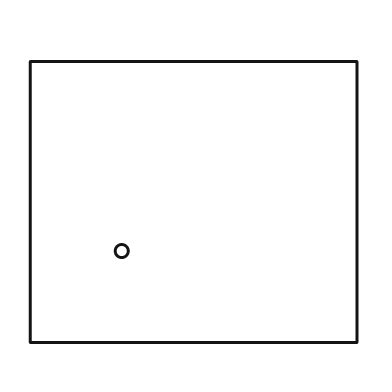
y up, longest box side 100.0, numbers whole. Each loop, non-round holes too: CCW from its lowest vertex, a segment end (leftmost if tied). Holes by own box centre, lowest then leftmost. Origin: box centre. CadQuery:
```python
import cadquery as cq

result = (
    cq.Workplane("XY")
    .moveTo(-50.0, -43.0)
    .lineTo(50.0, -43.0)
    .lineTo(50.0, 43.0)
    .lineTo(-50.0, 43.0)
    .close()
    .moveTo(-22.0, -15.0)
    .circle(2.0)
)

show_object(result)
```